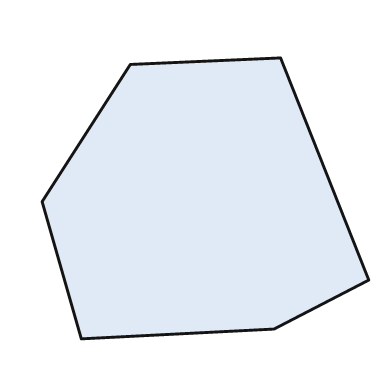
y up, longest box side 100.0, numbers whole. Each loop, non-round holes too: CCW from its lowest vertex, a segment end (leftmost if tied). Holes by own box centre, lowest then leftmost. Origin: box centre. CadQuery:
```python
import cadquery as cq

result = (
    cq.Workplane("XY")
    .moveTo(-38.0, -43.0)
    .lineTo(21.0, -40.0)
    .lineTo(50.0, -25.0)
    .lineTo(23.0, 43.0)
    .lineTo(-23.0, 41.0)
    .lineTo(-50.0, -1.0)
    .close()
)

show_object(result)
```